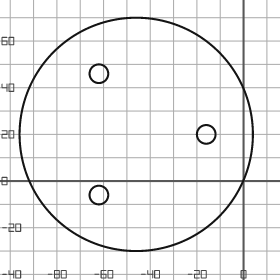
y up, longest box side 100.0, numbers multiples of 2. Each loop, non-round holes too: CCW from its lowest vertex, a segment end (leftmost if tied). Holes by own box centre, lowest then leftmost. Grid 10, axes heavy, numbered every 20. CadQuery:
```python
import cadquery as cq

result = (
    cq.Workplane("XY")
    .moveTo(-46.0, 20.0)
    .circle(50.0)
    .moveTo(-62.0, -6.0)
    .circle(4.0)
    .moveTo(-16.0, 20.0)
    .circle(4.0)
    .moveTo(-62.0, 46.0)
    .circle(4.0)
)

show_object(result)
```